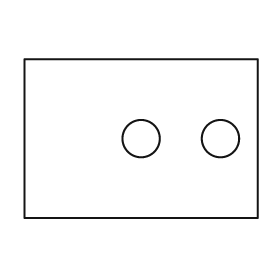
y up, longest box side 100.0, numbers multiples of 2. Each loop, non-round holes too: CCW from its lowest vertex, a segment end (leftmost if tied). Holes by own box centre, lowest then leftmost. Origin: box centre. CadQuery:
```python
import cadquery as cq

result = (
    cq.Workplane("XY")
    .moveTo(-50.0, -34.0)
    .lineTo(50.0, -34.0)
    .lineTo(50.0, 34.0)
    .lineTo(-50.0, 34.0)
    .close()
    .moveTo(0.0, 0.0)
    .circle(8.0)
    .moveTo(34.0, 0.0)
    .circle(8.0)
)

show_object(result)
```